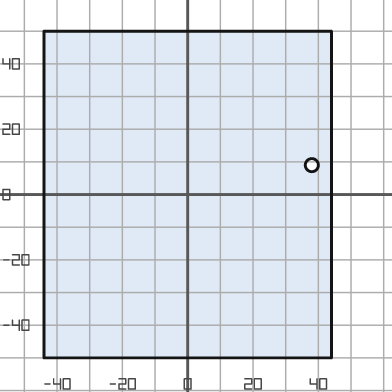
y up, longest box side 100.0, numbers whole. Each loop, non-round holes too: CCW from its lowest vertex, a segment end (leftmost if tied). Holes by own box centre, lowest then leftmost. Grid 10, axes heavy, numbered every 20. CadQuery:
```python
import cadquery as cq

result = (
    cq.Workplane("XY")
    .moveTo(-44.0, -50.0)
    .lineTo(44.0, -50.0)
    .lineTo(44.0, 50.0)
    .lineTo(-44.0, 50.0)
    .close()
    .moveTo(38.0, 9.0)
    .circle(2.0)
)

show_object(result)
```